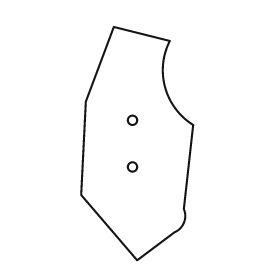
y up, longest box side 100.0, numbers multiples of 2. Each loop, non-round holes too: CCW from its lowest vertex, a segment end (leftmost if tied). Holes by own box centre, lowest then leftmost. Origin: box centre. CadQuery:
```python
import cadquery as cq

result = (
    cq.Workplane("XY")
    .moveTo(0.0, -50.0)
    .lineTo(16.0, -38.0)
    .threePointArc((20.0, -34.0), (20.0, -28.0))
    .lineTo(24.0, 8.0)
    .threePointArc((12.0, 24.0), (14.0, 44.0))
    .lineTo(-10.0, 50.0)
    .lineTo(-22.0, 18.0)
    .lineTo(-24.0, -22.0)
    .close()
    .moveTo(-2.0, -10.0)
    .circle(2.0)
    .moveTo(-2.0, 10.0)
    .circle(2.0)
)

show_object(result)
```